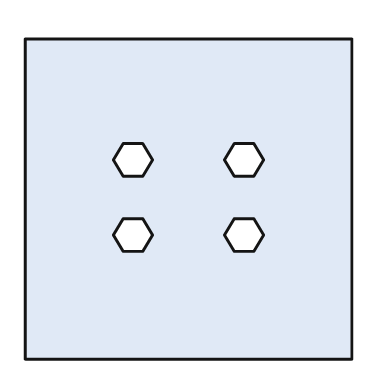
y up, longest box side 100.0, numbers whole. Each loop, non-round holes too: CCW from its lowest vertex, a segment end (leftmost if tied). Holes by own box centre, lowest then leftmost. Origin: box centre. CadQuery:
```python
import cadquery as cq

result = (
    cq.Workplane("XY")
    .moveTo(-50.0, -49.0)
    .lineTo(50.0, -49.0)
    .lineTo(50.0, 49.0)
    .lineTo(-50.0, 49.0)
    .close()
    .moveTo(-20.0, -16.0)
    .lineTo(-14.0, -16.0)
    .lineTo(-11.0, -11.0)
    .lineTo(-14.0, -6.0)
    .lineTo(-20.0, -6.0)
    .lineTo(-23.0, -11.0)
    .close()
    .moveTo(14.0, -16.0)
    .lineTo(20.0, -16.0)
    .lineTo(23.0, -11.0)
    .lineTo(20.0, -6.0)
    .lineTo(14.0, -6.0)
    .lineTo(11.0, -11.0)
    .close()
    .moveTo(-20.0, 7.0)
    .lineTo(-14.0, 7.0)
    .lineTo(-11.0, 12.0)
    .lineTo(-14.0, 17.0)
    .lineTo(-20.0, 17.0)
    .lineTo(-23.0, 12.0)
    .close()
    .moveTo(14.0, 7.0)
    .lineTo(20.0, 7.0)
    .lineTo(23.0, 12.0)
    .lineTo(20.0, 17.0)
    .lineTo(14.0, 17.0)
    .lineTo(11.0, 12.0)
    .close()
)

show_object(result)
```